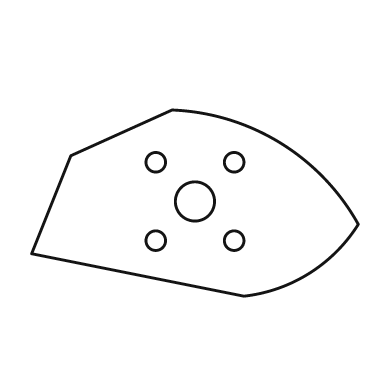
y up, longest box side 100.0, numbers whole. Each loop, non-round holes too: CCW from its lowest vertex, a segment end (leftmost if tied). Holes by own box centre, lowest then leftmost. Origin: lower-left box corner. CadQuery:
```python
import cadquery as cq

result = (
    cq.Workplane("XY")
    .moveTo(65.0, 0.0)
    .threePointArc((85.0, 7.0), (100.0, 22.0))
    .threePointArc((76.0, 47.0), (43.0, 57.0))
    .lineTo(12.0, 43.0)
    .lineTo(0.0, 13.0)
    .close()
    .moveTo(38.0, 17.0)
    .circle(3.0)
    .moveTo(62.0, 17.0)
    .circle(3.0)
    .moveTo(50.0, 29.0)
    .circle(6.0)
    .moveTo(38.0, 41.0)
    .circle(3.0)
    .moveTo(62.0, 41.0)
    .circle(3.0)
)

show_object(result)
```